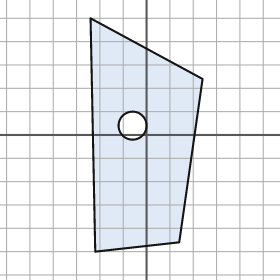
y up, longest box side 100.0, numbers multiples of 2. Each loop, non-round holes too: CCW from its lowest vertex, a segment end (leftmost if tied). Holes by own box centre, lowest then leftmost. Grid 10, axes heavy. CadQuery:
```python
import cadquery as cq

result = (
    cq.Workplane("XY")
    .moveTo(-22.0, -50.0)
    .lineTo(14.0, -46.0)
    .lineTo(24.0, 24.0)
    .lineTo(-24.0, 50.0)
    .close()
    .moveTo(-6.0, 4.0)
    .circle(6.0)
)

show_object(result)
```